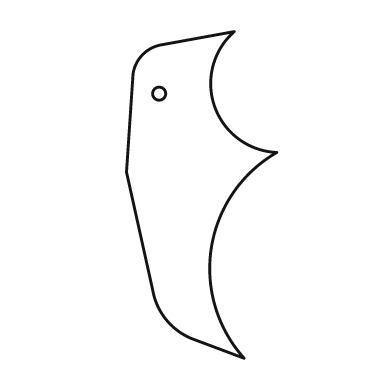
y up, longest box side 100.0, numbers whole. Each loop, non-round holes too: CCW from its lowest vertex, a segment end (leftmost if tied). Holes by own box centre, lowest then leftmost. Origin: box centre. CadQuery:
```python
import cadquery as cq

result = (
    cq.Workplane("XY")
    .moveTo(13.0, -50.0)
    .threePointArc((3.0, -16.0), (23.0, 13.0))
    .threePointArc((4.0, 27.0), (10.0, 50.0))
    .lineTo(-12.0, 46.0)
    .threePointArc((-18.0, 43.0), (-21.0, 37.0))
    .lineTo(-23.0, 7.0)
    .lineTo(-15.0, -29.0)
    .threePointArc((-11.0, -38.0), (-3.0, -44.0))
    .close()
    .moveTo(-13.0, 31.0)
    .circle(2.0)
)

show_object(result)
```